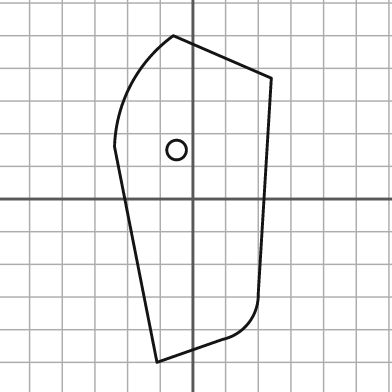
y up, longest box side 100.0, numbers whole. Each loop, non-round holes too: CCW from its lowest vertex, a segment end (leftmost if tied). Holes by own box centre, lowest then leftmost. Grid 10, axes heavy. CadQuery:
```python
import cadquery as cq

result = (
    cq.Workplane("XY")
    .moveTo(-11.0, -50.0)
    .lineTo(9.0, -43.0)
    .threePointArc((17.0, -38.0), (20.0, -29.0))
    .lineTo(24.0, 37.0)
    .lineTo(-6.0, 50.0)
    .threePointArc((-19.0, 35.0), (-24.0, 16.0))
    .close()
    .moveTo(-5.0, 15.0)
    .circle(3.0)
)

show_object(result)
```